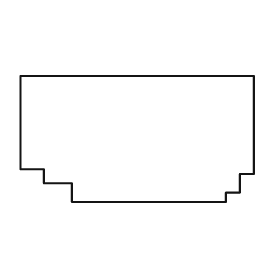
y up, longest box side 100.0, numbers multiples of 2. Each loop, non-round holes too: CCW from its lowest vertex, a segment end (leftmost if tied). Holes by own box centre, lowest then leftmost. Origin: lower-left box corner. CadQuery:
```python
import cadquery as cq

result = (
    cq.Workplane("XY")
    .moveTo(22.0, 0.0)
    .lineTo(88.0, 0.0)
    .lineTo(88.0, 4.0)
    .lineTo(94.0, 4.0)
    .lineTo(94.0, 12.0)
    .lineTo(100.0, 12.0)
    .lineTo(100.0, 54.0)
    .lineTo(0.0, 54.0)
    .lineTo(0.0, 14.0)
    .lineTo(10.0, 14.0)
    .lineTo(10.0, 8.0)
    .lineTo(22.0, 8.0)
    .close()
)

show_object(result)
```